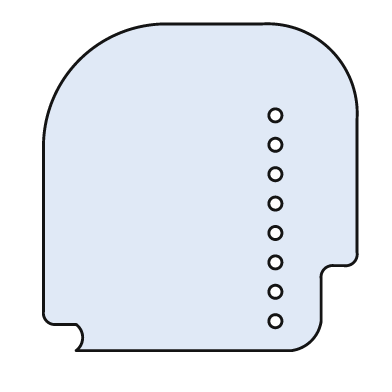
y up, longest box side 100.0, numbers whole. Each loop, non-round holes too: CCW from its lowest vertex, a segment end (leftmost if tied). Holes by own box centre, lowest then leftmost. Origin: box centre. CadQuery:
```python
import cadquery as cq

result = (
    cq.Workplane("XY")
    .moveTo(-38.0, -50.0)
    .lineTo(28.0, -50.0)
    .threePointArc((34.0, -47.0), (37.0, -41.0))
    .lineTo(37.0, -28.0)
    .threePointArc((38.0, -25.0), (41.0, -24.0))
    .lineTo(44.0, -24.0)
    .threePointArc((47.0, -23.0), (48.0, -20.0))
    .lineTo(48.0, 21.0)
    .threePointArc((40.0, 42.0), (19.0, 50.0))
    .lineTo(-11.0, 50.0)
    .threePointArc((-37.0, 39.0), (-48.0, 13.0))
    .lineTo(-48.0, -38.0)
    .threePointArc((-47.0, -41.0), (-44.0, -42.0))
    .lineTo(-38.0, -42.0)
    .threePointArc((-36.0, -46.0), (-38.0, -50.0))
    .close()
    .moveTo(23.0, -41.0)
    .circle(2.0)
    .moveTo(23.0, -32.0)
    .circle(2.0)
    .moveTo(23.0, -23.0)
    .circle(2.0)
    .moveTo(23.0, -14.0)
    .circle(2.0)
    .moveTo(23.0, -5.0)
    .circle(2.0)
    .moveTo(23.0, 4.0)
    .circle(2.0)
    .moveTo(23.0, 13.0)
    .circle(2.0)
    .moveTo(23.0, 22.0)
    .circle(2.0)
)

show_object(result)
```